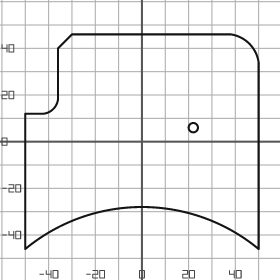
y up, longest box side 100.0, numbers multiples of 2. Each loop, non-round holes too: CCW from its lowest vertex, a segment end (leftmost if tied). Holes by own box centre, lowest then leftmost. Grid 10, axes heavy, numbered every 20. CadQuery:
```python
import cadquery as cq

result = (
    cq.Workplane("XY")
    .moveTo(-50.0, -46.0)
    .threePointArc((0.0, -28.0), (50.0, -46.0))
    .lineTo(50.0, 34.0)
    .threePointArc((46.0, 42.0), (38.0, 46.0))
    .lineTo(-30.0, 46.0)
    .lineTo(-36.0, 40.0)
    .lineTo(-36.0, 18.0)
    .threePointArc((-38.0, 14.0), (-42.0, 12.0))
    .lineTo(-50.0, 12.0)
    .close()
    .moveTo(22.0, 6.0)
    .circle(2.0)
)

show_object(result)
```